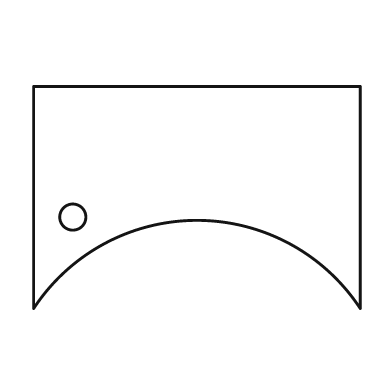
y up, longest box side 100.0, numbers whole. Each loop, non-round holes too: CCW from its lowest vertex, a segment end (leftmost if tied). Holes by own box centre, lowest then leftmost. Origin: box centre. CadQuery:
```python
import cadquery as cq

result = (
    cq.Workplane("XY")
    .moveTo(-50.0, -34.0)
    .threePointArc((0.0, -7.0), (50.0, -34.0))
    .lineTo(50.0, 34.0)
    .lineTo(-50.0, 34.0)
    .close()
    .moveTo(-38.0, -6.0)
    .circle(4.0)
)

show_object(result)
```